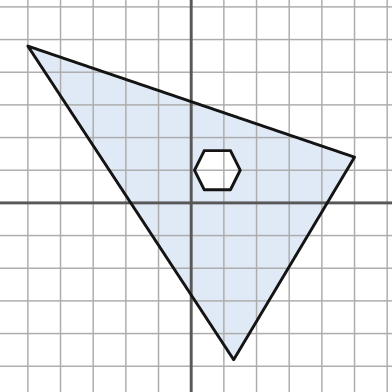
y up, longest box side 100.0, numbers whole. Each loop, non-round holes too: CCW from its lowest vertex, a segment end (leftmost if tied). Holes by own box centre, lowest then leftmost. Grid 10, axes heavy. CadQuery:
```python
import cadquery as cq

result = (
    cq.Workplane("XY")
    .moveTo(13.0, -48.0)
    .lineTo(50.0, 14.0)
    .lineTo(-50.0, 48.0)
    .close()
    .moveTo(4.0, 4.0)
    .lineTo(12.0, 4.0)
    .lineTo(15.0, 10.0)
    .lineTo(12.0, 16.0)
    .lineTo(4.0, 16.0)
    .lineTo(1.0, 10.0)
    .close()
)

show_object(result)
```